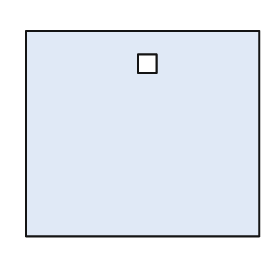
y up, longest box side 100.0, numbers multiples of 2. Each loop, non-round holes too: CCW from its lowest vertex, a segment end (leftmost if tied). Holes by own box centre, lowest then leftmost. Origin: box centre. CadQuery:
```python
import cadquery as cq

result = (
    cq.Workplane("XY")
    .moveTo(-50.0, -44.0)
    .lineTo(50.0, -44.0)
    .lineTo(50.0, 44.0)
    .lineTo(-50.0, 44.0)
    .close()
    .moveTo(-2.0, 26.0)
    .lineTo(6.0, 26.0)
    .lineTo(6.0, 34.0)
    .lineTo(-2.0, 34.0)
    .close()
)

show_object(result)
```